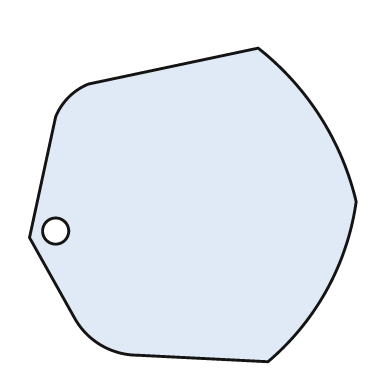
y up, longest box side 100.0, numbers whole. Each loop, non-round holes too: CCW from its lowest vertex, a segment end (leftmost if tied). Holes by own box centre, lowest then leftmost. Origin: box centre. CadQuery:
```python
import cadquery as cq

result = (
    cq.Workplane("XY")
    .moveTo(23.0, -48.0)
    .threePointArc((41.0, -26.0), (50.0, 1.0))
    .threePointArc((39.0, 27.0), (20.0, 48.0))
    .lineTo(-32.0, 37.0)
    .threePointArc((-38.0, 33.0), (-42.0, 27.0))
    .lineTo(-50.0, -10.0)
    .lineTo(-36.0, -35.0)
    .threePointArc((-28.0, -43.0), (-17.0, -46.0))
    .close()
    .moveTo(-42.0, -8.0)
    .circle(4.0)
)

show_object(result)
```